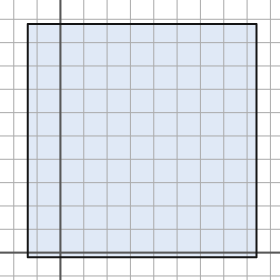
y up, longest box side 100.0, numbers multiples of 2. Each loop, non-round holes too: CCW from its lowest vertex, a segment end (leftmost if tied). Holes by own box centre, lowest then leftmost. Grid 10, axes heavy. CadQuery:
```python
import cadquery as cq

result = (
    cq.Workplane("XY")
    .moveTo(-14.0, -2.0)
    .lineTo(84.0, -2.0)
    .lineTo(84.0, 98.0)
    .lineTo(-14.0, 98.0)
    .close()
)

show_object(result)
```